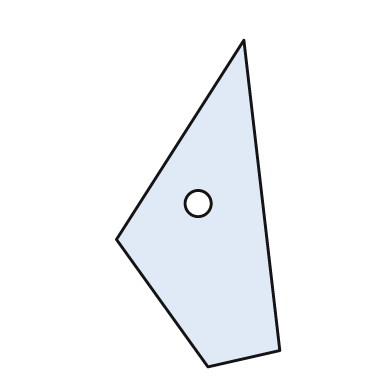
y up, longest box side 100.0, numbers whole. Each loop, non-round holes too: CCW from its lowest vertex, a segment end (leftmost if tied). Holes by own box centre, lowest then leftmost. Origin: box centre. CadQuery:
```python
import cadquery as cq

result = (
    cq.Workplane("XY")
    .moveTo(3.0, -50.0)
    .lineTo(25.0, -45.0)
    .lineTo(14.0, 50.0)
    .lineTo(-25.0, -11.0)
    .close()
    .moveTo(0.0, 0.0)
    .circle(4.0)
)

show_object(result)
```